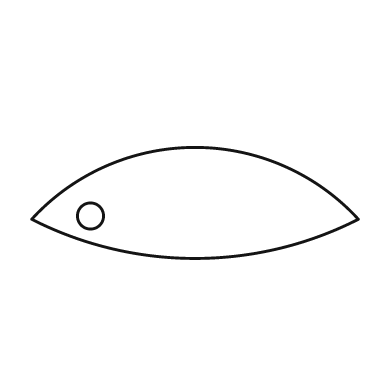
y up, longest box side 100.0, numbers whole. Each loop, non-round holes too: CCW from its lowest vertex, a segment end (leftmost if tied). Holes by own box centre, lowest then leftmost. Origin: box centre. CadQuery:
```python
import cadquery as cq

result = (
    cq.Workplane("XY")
    .moveTo(-50.0, -5.0)
    .threePointArc((0.0, -17.0), (50.0, -5.0))
    .threePointArc((0.0, 17.0), (-50.0, -5.0))
    .close()
    .moveTo(-32.0, -4.0)
    .circle(4.0)
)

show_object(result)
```